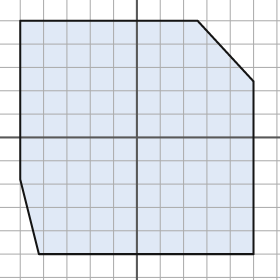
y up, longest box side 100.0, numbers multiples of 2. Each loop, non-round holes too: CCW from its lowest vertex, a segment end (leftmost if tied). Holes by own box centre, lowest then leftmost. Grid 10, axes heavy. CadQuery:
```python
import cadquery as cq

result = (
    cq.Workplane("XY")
    .moveTo(-42.0, -50.0)
    .lineTo(50.0, -50.0)
    .lineTo(50.0, 24.0)
    .lineTo(26.0, 50.0)
    .lineTo(-50.0, 50.0)
    .lineTo(-50.0, -18.0)
    .close()
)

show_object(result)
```